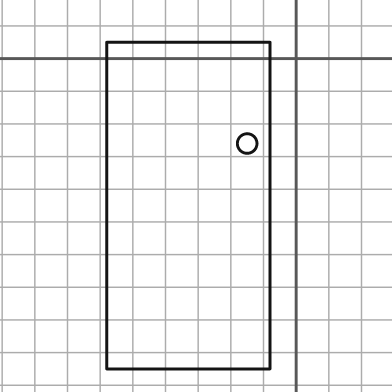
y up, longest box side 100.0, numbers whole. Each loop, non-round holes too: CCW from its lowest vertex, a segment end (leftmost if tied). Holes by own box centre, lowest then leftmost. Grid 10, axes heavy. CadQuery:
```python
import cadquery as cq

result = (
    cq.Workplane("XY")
    .moveTo(-58.0, -95.0)
    .lineTo(-8.0, -95.0)
    .lineTo(-8.0, 5.0)
    .lineTo(-58.0, 5.0)
    .close()
    .moveTo(-15.0, -26.0)
    .circle(3.0)
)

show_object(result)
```